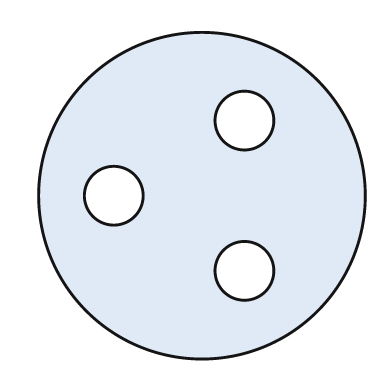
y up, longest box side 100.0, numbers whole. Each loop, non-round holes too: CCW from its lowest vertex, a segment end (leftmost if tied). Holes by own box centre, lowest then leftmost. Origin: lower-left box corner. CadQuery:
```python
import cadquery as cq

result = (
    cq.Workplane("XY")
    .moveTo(50.0, 50.0)
    .circle(50.0)
    .moveTo(63.0, 27.0)
    .circle(9.0)
    .moveTo(23.0, 50.0)
    .circle(9.0)
    .moveTo(63.0, 73.0)
    .circle(9.0)
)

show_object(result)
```